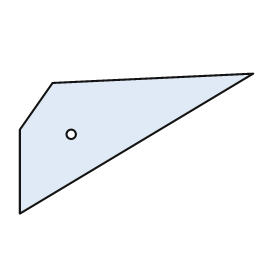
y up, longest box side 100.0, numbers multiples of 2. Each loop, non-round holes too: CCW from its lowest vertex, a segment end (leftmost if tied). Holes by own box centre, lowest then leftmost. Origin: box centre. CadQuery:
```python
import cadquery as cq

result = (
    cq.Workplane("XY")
    .moveTo(-50.0, -30.0)
    .lineTo(50.0, 30.0)
    .lineTo(-36.0, 26.0)
    .lineTo(-50.0, 6.0)
    .close()
    .moveTo(-28.0, 4.0)
    .circle(2.0)
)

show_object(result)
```